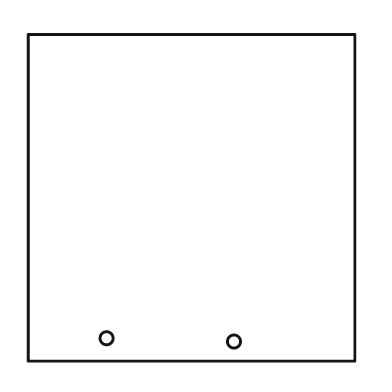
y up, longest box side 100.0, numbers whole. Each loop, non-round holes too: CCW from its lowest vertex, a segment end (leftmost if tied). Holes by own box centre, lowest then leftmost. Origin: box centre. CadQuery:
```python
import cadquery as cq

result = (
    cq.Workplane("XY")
    .moveTo(-50.0, -50.0)
    .lineTo(50.0, -50.0)
    .lineTo(50.0, 50.0)
    .lineTo(-50.0, 50.0)
    .close()
    .moveTo(13.0, -44.0)
    .circle(2.0)
    .moveTo(-26.0, -43.0)
    .circle(2.0)
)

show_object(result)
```